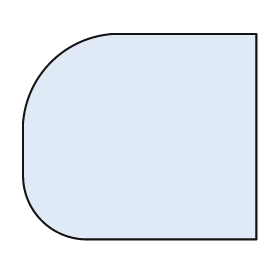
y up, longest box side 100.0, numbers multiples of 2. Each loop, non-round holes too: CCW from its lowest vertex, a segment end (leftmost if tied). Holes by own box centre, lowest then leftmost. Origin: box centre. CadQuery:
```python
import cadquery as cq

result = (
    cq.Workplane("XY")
    .moveTo(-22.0, -44.0)
    .lineTo(50.0, -44.0)
    .lineTo(50.0, 44.0)
    .lineTo(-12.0, 44.0)
    .threePointArc((-38.0, 32.0), (-50.0, 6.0))
    .lineTo(-50.0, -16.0)
    .threePointArc((-42.0, -36.0), (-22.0, -44.0))
    .close()
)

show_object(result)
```